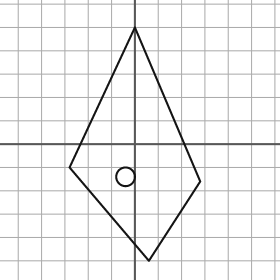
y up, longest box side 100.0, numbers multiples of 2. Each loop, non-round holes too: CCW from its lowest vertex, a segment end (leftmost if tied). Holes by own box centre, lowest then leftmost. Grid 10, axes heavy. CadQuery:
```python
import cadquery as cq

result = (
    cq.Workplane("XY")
    .moveTo(6.0, -50.0)
    .lineTo(28.0, -16.0)
    .lineTo(0.0, 50.0)
    .lineTo(-28.0, -10.0)
    .close()
    .moveTo(-4.0, -14.0)
    .circle(4.0)
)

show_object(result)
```